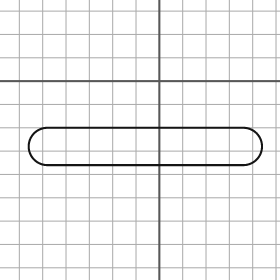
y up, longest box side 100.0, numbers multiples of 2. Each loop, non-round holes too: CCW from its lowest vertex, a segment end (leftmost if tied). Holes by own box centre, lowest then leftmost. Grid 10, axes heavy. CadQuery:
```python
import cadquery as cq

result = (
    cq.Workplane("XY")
    .moveTo(-48.0, -36.0)
    .lineTo(36.0, -36.0)
    .threePointArc((44.0, -28.0), (36.0, -20.0))
    .lineTo(-48.0, -20.0)
    .threePointArc((-56.0, -28.0), (-48.0, -36.0))
    .close()
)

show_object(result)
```